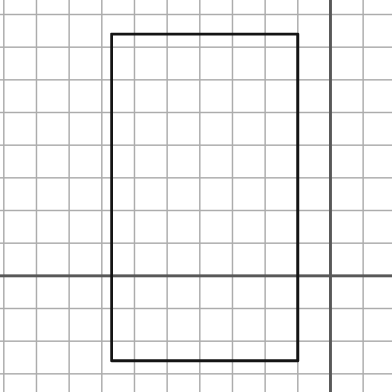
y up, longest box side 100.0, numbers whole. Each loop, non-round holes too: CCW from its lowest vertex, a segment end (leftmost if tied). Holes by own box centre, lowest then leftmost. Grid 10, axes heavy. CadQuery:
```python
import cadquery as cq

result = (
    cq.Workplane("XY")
    .moveTo(-67.0, -26.0)
    .lineTo(-10.0, -26.0)
    .lineTo(-10.0, 74.0)
    .lineTo(-67.0, 74.0)
    .close()
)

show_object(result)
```